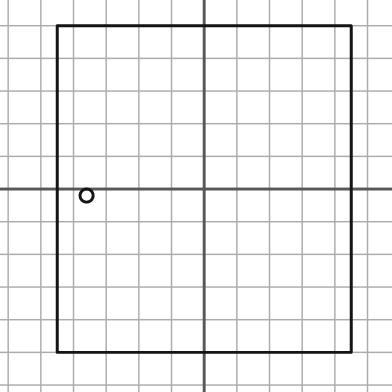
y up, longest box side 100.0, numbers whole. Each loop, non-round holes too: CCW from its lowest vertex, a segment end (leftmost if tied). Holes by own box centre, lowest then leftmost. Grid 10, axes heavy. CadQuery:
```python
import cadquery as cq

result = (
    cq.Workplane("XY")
    .moveTo(-45.0, -50.0)
    .lineTo(45.0, -50.0)
    .lineTo(45.0, 50.0)
    .lineTo(-45.0, 50.0)
    .close()
    .moveTo(-36.0, -2.0)
    .circle(2.0)
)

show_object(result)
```